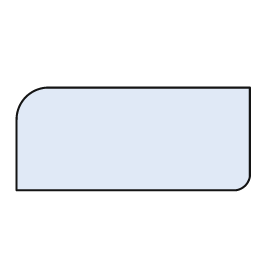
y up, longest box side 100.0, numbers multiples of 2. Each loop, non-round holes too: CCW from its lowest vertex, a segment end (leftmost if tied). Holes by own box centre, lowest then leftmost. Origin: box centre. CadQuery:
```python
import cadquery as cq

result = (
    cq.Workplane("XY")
    .moveTo(-50.0, -22.0)
    .lineTo(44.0, -22.0)
    .threePointArc((48.0, -20.0), (50.0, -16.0))
    .lineTo(50.0, 22.0)
    .lineTo(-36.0, 22.0)
    .threePointArc((-46.0, 18.0), (-50.0, 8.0))
    .close()
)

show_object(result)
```